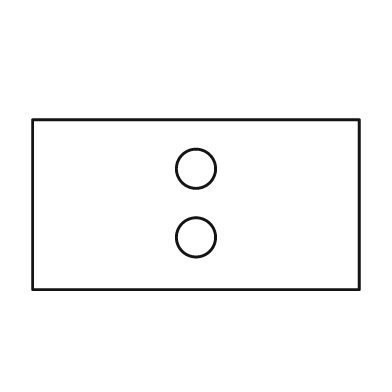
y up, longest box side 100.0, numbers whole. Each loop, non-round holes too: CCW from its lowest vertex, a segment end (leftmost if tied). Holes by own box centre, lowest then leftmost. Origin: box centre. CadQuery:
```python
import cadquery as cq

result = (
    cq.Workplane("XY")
    .moveTo(-50.0, -26.0)
    .lineTo(50.0, -26.0)
    .lineTo(50.0, 26.0)
    .lineTo(-50.0, 26.0)
    .close()
    .moveTo(0.0, -10.0)
    .circle(6.0)
    .moveTo(0.0, 11.0)
    .circle(6.0)
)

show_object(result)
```